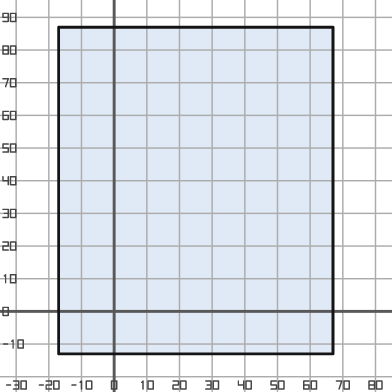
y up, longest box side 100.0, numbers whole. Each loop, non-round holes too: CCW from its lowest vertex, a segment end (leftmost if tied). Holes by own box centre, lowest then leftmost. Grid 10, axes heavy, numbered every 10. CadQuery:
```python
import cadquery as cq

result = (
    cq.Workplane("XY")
    .moveTo(-17.0, -13.0)
    .lineTo(67.0, -13.0)
    .lineTo(67.0, 87.0)
    .lineTo(-17.0, 87.0)
    .close()
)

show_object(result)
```